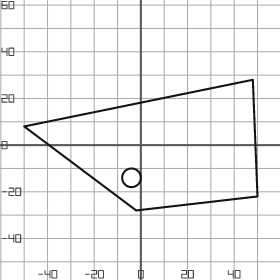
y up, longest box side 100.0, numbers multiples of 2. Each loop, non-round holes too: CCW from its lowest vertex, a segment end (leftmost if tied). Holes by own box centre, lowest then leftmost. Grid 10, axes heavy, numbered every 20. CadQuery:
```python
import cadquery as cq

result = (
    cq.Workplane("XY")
    .moveTo(-2.0, -28.0)
    .lineTo(50.0, -22.0)
    .lineTo(48.0, 28.0)
    .lineTo(-50.0, 8.0)
    .close()
    .moveTo(-4.0, -14.0)
    .circle(4.0)
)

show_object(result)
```